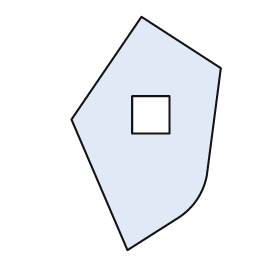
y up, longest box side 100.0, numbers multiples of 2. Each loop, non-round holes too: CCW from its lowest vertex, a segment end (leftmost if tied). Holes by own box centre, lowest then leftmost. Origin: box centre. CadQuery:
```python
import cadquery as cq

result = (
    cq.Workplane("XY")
    .moveTo(-8.0, -50.0)
    .lineTo(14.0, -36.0)
    .threePointArc((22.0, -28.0), (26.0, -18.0))
    .lineTo(32.0, 28.0)
    .lineTo(-2.0, 50.0)
    .lineTo(-32.0, 6.0)
    .close()
    .moveTo(-6.0, 0.0)
    .lineTo(10.0, 0.0)
    .lineTo(10.0, 16.0)
    .lineTo(-6.0, 16.0)
    .close()
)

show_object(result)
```